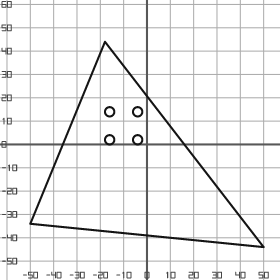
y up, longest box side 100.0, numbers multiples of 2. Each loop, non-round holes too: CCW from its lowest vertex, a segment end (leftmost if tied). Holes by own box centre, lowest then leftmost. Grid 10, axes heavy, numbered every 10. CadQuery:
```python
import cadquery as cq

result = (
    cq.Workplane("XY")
    .moveTo(50.0, -44.0)
    .lineTo(-18.0, 44.0)
    .lineTo(-50.0, -34.0)
    .close()
    .moveTo(-16.0, 2.0)
    .circle(2.0)
    .moveTo(-4.0, 2.0)
    .circle(2.0)
    .moveTo(-16.0, 14.0)
    .circle(2.0)
    .moveTo(-4.0, 14.0)
    .circle(2.0)
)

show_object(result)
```